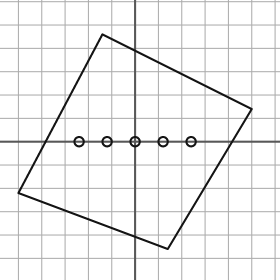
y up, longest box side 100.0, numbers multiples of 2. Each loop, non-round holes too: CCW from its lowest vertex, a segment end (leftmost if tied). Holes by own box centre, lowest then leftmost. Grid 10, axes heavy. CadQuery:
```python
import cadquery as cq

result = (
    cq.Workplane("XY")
    .moveTo(14.0, -46.0)
    .lineTo(50.0, 14.0)
    .lineTo(-14.0, 46.0)
    .lineTo(-50.0, -22.0)
    .close()
    .moveTo(-24.0, 0.0)
    .circle(2.0)
    .moveTo(-12.0, 0.0)
    .circle(2.0)
    .moveTo(0.0, 0.0)
    .circle(2.0)
    .moveTo(12.0, 0.0)
    .circle(2.0)
    .moveTo(24.0, 0.0)
    .circle(2.0)
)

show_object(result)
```